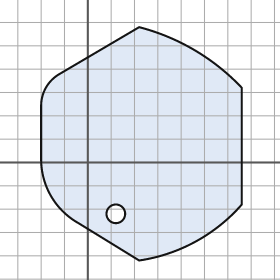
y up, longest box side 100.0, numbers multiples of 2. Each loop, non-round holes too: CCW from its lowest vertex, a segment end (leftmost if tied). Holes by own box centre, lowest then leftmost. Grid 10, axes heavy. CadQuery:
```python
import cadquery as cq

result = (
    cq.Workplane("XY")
    .moveTo(22.0, -42.0)
    .threePointArc((46.0, -34.0), (66.0, -18.0))
    .lineTo(66.0, 32.0)
    .threePointArc((46.0, 48.0), (22.0, 58.0))
    .lineTo(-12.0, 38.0)
    .threePointArc((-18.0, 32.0), (-20.0, 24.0))
    .lineTo(-20.0, 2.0)
    .threePointArc((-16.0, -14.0), (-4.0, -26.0))
    .close()
    .moveTo(12.0, -22.0)
    .circle(4.0)
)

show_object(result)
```